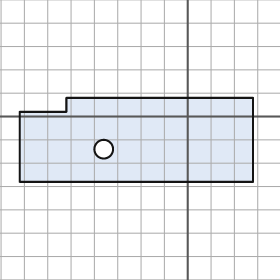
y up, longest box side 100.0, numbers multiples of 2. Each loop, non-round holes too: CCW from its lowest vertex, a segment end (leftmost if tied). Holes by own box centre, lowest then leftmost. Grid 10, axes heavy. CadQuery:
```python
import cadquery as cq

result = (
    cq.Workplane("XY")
    .moveTo(-72.0, -28.0)
    .lineTo(28.0, -28.0)
    .lineTo(28.0, 8.0)
    .lineTo(-52.0, 8.0)
    .lineTo(-52.0, 2.0)
    .lineTo(-72.0, 2.0)
    .close()
    .moveTo(-36.0, -14.0)
    .circle(4.0)
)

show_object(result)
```